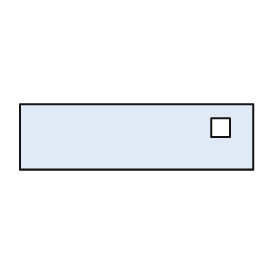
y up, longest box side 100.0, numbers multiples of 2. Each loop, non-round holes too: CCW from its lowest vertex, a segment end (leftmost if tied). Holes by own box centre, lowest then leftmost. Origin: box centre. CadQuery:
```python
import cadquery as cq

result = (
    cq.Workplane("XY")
    .moveTo(-50.0, -14.0)
    .lineTo(50.0, -14.0)
    .lineTo(50.0, 14.0)
    .lineTo(-50.0, 14.0)
    .close()
    .moveTo(32.0, 0.0)
    .lineTo(40.0, 0.0)
    .lineTo(40.0, 8.0)
    .lineTo(32.0, 8.0)
    .close()
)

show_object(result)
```